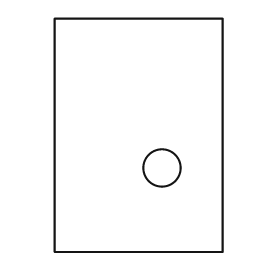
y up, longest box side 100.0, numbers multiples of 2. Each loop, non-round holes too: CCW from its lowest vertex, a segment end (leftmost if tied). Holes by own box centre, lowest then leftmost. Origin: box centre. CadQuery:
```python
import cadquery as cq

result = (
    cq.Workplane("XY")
    .moveTo(-36.0, -50.0)
    .lineTo(36.0, -50.0)
    .lineTo(36.0, 50.0)
    .lineTo(-36.0, 50.0)
    .close()
    .moveTo(10.0, -14.0)
    .circle(8.0)
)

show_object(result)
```